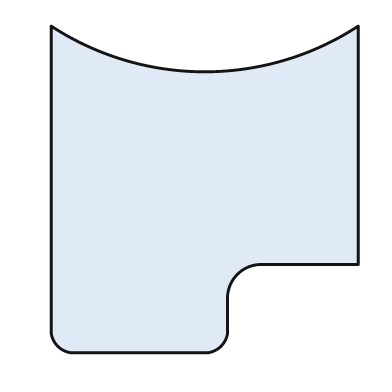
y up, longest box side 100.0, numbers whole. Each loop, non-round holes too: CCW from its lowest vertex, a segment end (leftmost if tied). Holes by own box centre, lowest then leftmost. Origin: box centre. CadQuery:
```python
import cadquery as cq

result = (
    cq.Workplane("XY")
    .moveTo(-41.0, -50.0)
    .lineTo(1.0, -50.0)
    .threePointArc((5.0, -48.0), (7.0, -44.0))
    .lineTo(7.0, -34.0)
    .threePointArc((10.0, -26.0), (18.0, -23.0))
    .lineTo(47.0, -23.0)
    .lineTo(47.0, 50.0)
    .threePointArc((0.0, 36.0), (-47.0, 50.0))
    .lineTo(-47.0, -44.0)
    .threePointArc((-45.0, -48.0), (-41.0, -50.0))
    .close()
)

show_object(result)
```